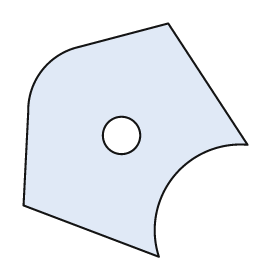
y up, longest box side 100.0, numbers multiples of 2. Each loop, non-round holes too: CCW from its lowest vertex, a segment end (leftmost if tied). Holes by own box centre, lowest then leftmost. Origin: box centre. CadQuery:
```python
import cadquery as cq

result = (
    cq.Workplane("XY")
    .moveTo(10.0, -50.0)
    .threePointArc((16.0, -16.0), (48.0, -2.0))
    .lineTo(14.0, 50.0)
    .lineTo(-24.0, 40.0)
    .threePointArc((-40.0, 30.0), (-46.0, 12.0))
    .lineTo(-48.0, -28.0)
    .close()
    .moveTo(-6.0, 2.0)
    .circle(8.0)
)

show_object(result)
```